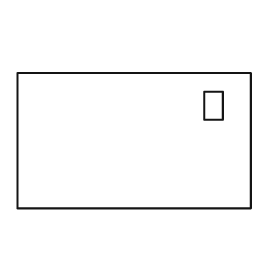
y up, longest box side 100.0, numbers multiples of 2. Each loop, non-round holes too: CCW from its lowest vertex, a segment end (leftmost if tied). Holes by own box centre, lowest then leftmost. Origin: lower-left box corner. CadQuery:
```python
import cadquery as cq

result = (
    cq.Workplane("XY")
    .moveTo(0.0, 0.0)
    .lineTo(100.0, 0.0)
    .lineTo(100.0, 58.0)
    .lineTo(0.0, 58.0)
    .close()
    .moveTo(80.0, 38.0)
    .lineTo(88.0, 38.0)
    .lineTo(88.0, 50.0)
    .lineTo(80.0, 50.0)
    .close()
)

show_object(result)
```